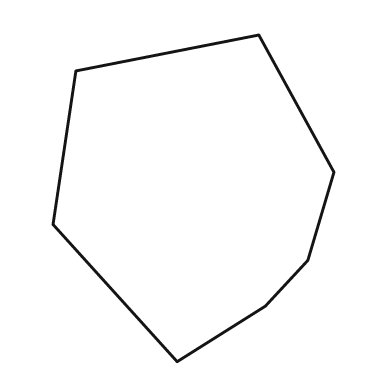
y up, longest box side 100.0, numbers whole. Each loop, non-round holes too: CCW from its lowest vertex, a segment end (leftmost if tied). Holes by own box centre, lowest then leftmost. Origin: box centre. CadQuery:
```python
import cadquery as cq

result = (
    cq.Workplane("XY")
    .moveTo(-5.0, -50.0)
    .lineTo(22.0, -33.0)
    .lineTo(35.0, -19.0)
    .lineTo(43.0, 8.0)
    .lineTo(20.0, 50.0)
    .lineTo(-36.0, 39.0)
    .lineTo(-43.0, -8.0)
    .close()
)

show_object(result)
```